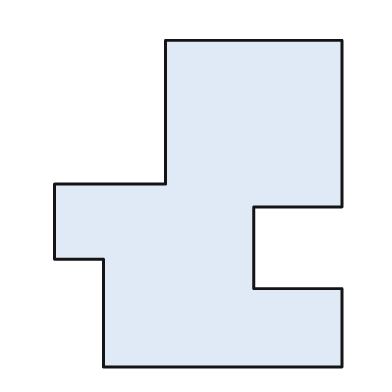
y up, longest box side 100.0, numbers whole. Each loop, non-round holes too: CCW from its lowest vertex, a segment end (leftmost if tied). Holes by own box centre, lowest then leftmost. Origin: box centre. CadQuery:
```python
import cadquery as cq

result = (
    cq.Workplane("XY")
    .moveTo(-29.0, -50.0)
    .lineTo(44.0, -50.0)
    .lineTo(44.0, -26.0)
    .lineTo(17.0, -26.0)
    .lineTo(17.0, -1.0)
    .lineTo(44.0, -1.0)
    .lineTo(44.0, 50.0)
    .lineTo(-10.0, 50.0)
    .lineTo(-10.0, 6.0)
    .lineTo(-44.0, 6.0)
    .lineTo(-44.0, -17.0)
    .lineTo(-29.0, -17.0)
    .close()
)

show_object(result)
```